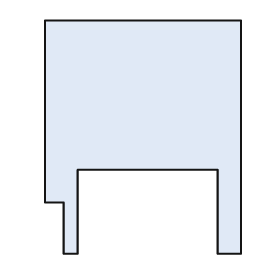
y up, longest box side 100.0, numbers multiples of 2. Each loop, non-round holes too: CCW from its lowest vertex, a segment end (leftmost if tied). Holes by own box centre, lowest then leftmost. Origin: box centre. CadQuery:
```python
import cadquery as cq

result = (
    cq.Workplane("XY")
    .moveTo(-34.0, -50.0)
    .lineTo(-28.0, -50.0)
    .lineTo(-28.0, -14.0)
    .lineTo(32.0, -14.0)
    .lineTo(32.0, -50.0)
    .lineTo(42.0, -50.0)
    .lineTo(42.0, 50.0)
    .lineTo(-42.0, 50.0)
    .lineTo(-42.0, -28.0)
    .lineTo(-34.0, -28.0)
    .close()
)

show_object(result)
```